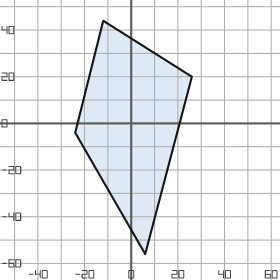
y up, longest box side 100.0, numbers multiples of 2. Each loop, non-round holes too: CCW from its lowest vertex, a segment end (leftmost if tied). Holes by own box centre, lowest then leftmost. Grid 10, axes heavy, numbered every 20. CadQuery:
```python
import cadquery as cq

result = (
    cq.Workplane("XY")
    .moveTo(6.0, -56.0)
    .lineTo(26.0, 20.0)
    .lineTo(-12.0, 44.0)
    .lineTo(-24.0, -4.0)
    .close()
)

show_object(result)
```